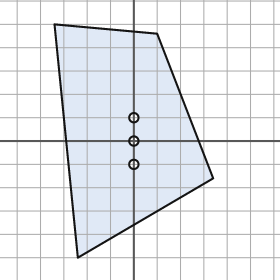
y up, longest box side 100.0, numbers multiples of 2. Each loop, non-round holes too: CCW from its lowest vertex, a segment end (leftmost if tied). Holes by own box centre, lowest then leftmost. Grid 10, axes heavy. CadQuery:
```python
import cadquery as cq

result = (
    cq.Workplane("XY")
    .moveTo(-24.0, -50.0)
    .lineTo(34.0, -16.0)
    .lineTo(10.0, 46.0)
    .lineTo(-34.0, 50.0)
    .close()
    .moveTo(0.0, -10.0)
    .circle(2.0)
    .moveTo(0.0, 0.0)
    .circle(2.0)
    .moveTo(0.0, 10.0)
    .circle(2.0)
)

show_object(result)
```